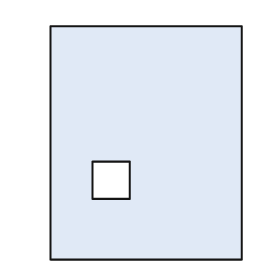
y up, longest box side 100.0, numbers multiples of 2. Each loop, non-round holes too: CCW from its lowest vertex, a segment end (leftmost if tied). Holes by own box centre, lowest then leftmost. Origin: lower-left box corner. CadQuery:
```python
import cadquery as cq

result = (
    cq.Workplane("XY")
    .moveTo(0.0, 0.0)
    .lineTo(82.0, 0.0)
    .lineTo(82.0, 100.0)
    .lineTo(0.0, 100.0)
    .close()
    .moveTo(18.0, 26.0)
    .lineTo(34.0, 26.0)
    .lineTo(34.0, 42.0)
    .lineTo(18.0, 42.0)
    .close()
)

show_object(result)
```